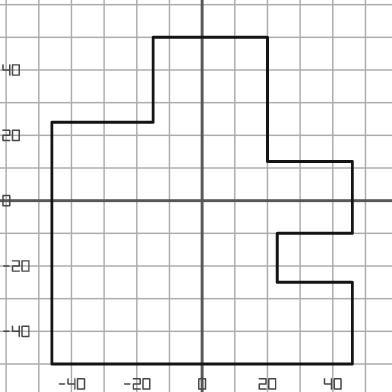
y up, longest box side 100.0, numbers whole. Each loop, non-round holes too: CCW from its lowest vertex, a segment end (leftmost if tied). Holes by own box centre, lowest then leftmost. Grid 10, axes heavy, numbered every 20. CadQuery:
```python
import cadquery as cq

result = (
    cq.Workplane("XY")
    .moveTo(-46.0, -50.0)
    .lineTo(46.0, -50.0)
    .lineTo(46.0, -25.0)
    .lineTo(23.0, -25.0)
    .lineTo(23.0, -10.0)
    .lineTo(46.0, -10.0)
    .lineTo(46.0, 12.0)
    .lineTo(20.0, 12.0)
    .lineTo(20.0, 50.0)
    .lineTo(-15.0, 50.0)
    .lineTo(-15.0, 24.0)
    .lineTo(-46.0, 24.0)
    .close()
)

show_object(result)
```